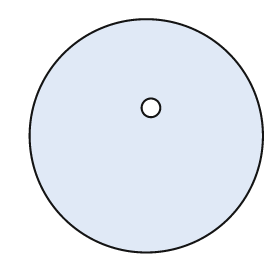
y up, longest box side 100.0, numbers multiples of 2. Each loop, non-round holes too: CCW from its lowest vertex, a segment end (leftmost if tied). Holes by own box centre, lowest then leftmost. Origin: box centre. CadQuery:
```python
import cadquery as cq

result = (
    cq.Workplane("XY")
    .moveTo(0.0, 0.0)
    .circle(50.0)
    .moveTo(2.0, 12.0)
    .circle(4.0)
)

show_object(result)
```